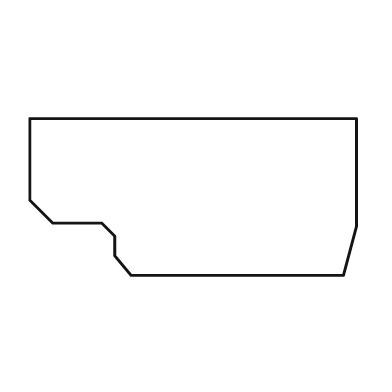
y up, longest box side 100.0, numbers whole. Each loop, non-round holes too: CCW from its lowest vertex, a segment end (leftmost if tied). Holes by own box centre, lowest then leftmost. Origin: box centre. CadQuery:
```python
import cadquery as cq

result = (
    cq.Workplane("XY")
    .moveTo(-19.0, -24.0)
    .lineTo(46.0, -24.0)
    .lineTo(50.0, -9.0)
    .lineTo(50.0, 24.0)
    .lineTo(-50.0, 24.0)
    .lineTo(-50.0, -1.0)
    .lineTo(-43.0, -8.0)
    .lineTo(-28.0, -8.0)
    .lineTo(-24.0, -12.0)
    .lineTo(-24.0, -18.0)
    .close()
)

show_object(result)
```